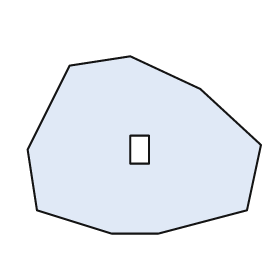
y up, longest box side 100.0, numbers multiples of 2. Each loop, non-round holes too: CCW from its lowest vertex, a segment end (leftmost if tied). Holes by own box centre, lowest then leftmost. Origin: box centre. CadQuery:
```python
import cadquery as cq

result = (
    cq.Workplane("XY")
    .moveTo(-14.0, -38.0)
    .lineTo(6.0, -38.0)
    .lineTo(44.0, -28.0)
    .lineTo(50.0, 0.0)
    .lineTo(24.0, 24.0)
    .lineTo(-6.0, 38.0)
    .lineTo(-32.0, 34.0)
    .lineTo(-50.0, -2.0)
    .lineTo(-46.0, -28.0)
    .close()
    .moveTo(-6.0, -8.0)
    .lineTo(2.0, -8.0)
    .lineTo(2.0, 4.0)
    .lineTo(-6.0, 4.0)
    .close()
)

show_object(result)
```